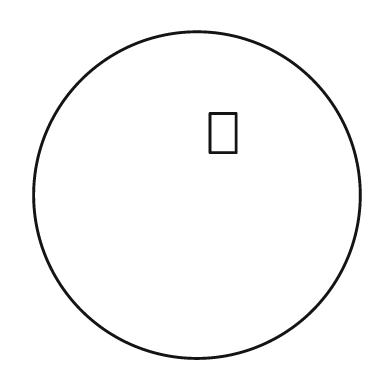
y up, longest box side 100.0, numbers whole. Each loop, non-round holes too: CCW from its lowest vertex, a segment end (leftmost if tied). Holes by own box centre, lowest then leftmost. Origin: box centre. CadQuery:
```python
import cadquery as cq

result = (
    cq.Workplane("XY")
    .moveTo(0.0, 0.0)
    .circle(50.0)
    .moveTo(4.0, 13.0)
    .lineTo(12.0, 13.0)
    .lineTo(12.0, 25.0)
    .lineTo(4.0, 25.0)
    .close()
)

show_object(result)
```